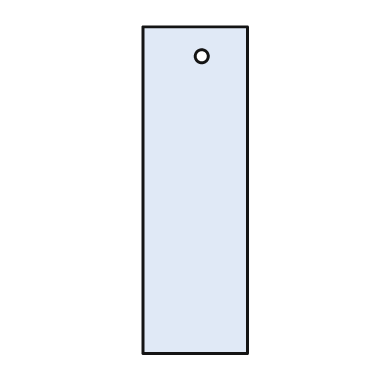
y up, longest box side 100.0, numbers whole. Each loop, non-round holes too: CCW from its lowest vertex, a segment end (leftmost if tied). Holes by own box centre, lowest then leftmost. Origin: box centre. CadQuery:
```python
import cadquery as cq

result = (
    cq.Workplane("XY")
    .moveTo(-16.0, -50.0)
    .lineTo(16.0, -50.0)
    .lineTo(16.0, 50.0)
    .lineTo(-16.0, 50.0)
    .close()
    .moveTo(2.0, 41.0)
    .circle(2.0)
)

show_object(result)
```